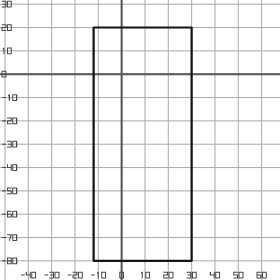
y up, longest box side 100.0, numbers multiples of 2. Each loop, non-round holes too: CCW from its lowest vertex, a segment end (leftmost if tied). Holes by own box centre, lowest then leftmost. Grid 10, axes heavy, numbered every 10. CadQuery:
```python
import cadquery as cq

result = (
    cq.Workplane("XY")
    .moveTo(-12.0, -80.0)
    .lineTo(30.0, -80.0)
    .lineTo(30.0, 20.0)
    .lineTo(-12.0, 20.0)
    .close()
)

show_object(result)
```